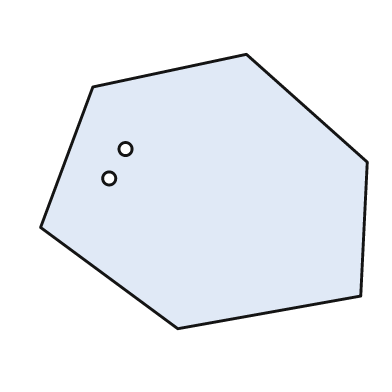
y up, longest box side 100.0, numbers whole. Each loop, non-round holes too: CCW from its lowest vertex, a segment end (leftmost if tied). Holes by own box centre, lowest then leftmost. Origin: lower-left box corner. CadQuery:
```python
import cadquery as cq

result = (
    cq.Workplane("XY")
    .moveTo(42.0, 0.0)
    .lineTo(98.0, 10.0)
    .lineTo(100.0, 51.0)
    .lineTo(63.0, 84.0)
    .lineTo(16.0, 74.0)
    .lineTo(0.0, 31.0)
    .close()
    .moveTo(21.0, 46.0)
    .circle(2.0)
    .moveTo(26.0, 55.0)
    .circle(2.0)
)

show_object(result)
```